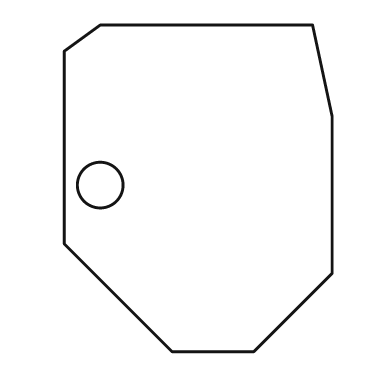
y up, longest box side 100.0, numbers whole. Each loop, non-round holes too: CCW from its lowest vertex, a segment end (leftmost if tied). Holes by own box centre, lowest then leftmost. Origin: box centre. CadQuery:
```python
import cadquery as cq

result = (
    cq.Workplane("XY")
    .moveTo(-8.0, -50.0)
    .lineTo(17.0, -50.0)
    .lineTo(41.0, -26.0)
    .lineTo(41.0, 22.0)
    .lineTo(35.0, 50.0)
    .lineTo(-30.0, 50.0)
    .lineTo(-41.0, 42.0)
    .lineTo(-41.0, -17.0)
    .close()
    .moveTo(-30.0, 1.0)
    .circle(7.0)
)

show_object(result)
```